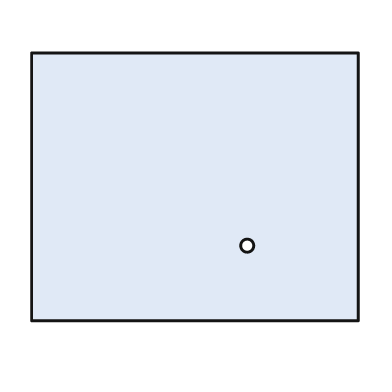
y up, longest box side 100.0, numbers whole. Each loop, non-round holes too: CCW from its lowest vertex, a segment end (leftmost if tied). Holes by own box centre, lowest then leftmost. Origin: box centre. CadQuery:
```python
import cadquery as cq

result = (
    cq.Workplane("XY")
    .moveTo(-50.0, -41.0)
    .lineTo(50.0, -41.0)
    .lineTo(50.0, 41.0)
    .lineTo(-50.0, 41.0)
    .close()
    .moveTo(16.0, -18.0)
    .circle(2.0)
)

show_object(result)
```